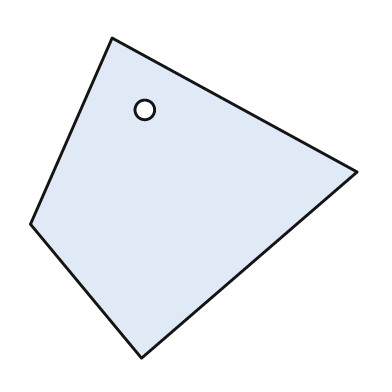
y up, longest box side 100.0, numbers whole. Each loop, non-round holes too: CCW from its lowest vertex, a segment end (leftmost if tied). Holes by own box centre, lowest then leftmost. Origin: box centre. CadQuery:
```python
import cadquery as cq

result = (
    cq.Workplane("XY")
    .moveTo(-16.0, -49.0)
    .lineTo(50.0, 8.0)
    .lineTo(-25.0, 49.0)
    .lineTo(-50.0, -8.0)
    .close()
    .moveTo(-15.0, 27.0)
    .circle(3.0)
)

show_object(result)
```